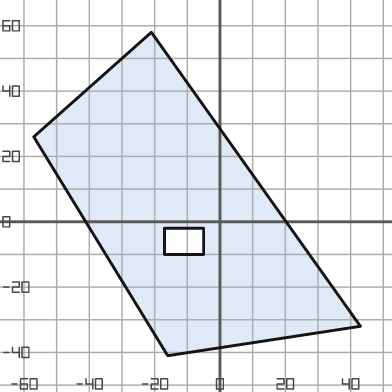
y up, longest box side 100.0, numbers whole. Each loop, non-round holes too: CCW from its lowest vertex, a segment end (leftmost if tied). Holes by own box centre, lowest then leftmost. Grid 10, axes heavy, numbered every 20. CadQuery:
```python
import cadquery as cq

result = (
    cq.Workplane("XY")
    .moveTo(-16.0, -41.0)
    .lineTo(43.0, -32.0)
    .lineTo(-21.0, 58.0)
    .lineTo(-57.0, 26.0)
    .close()
    .moveTo(-17.0, -10.0)
    .lineTo(-5.0, -10.0)
    .lineTo(-5.0, -2.0)
    .lineTo(-17.0, -2.0)
    .close()
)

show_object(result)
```